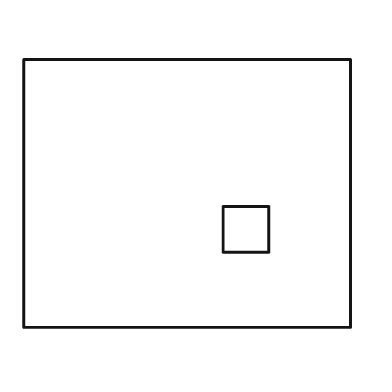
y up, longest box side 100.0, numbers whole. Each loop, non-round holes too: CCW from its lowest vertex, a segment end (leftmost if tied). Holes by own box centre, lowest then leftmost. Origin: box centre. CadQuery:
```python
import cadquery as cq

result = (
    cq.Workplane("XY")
    .moveTo(-50.0, -41.0)
    .lineTo(50.0, -41.0)
    .lineTo(50.0, 41.0)
    .lineTo(-50.0, 41.0)
    .close()
    .moveTo(11.0, -18.0)
    .lineTo(25.0, -18.0)
    .lineTo(25.0, -4.0)
    .lineTo(11.0, -4.0)
    .close()
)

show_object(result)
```